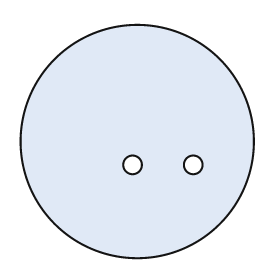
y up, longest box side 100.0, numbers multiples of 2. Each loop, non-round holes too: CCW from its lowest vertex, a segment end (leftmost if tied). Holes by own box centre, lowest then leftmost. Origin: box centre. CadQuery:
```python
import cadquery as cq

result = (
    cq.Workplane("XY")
    .moveTo(0.0, 0.0)
    .circle(50.0)
    .moveTo(-2.0, -10.0)
    .circle(4.0)
    .moveTo(24.0, -10.0)
    .circle(4.0)
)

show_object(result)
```